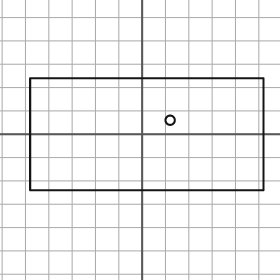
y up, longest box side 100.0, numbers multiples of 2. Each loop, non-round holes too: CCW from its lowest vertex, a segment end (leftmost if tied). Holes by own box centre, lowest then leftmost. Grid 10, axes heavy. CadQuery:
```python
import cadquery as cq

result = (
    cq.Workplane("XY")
    .moveTo(-48.0, -24.0)
    .lineTo(52.0, -24.0)
    .lineTo(52.0, 24.0)
    .lineTo(-48.0, 24.0)
    .close()
    .moveTo(12.0, 6.0)
    .circle(2.0)
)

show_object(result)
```